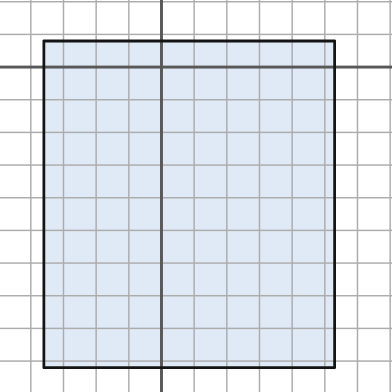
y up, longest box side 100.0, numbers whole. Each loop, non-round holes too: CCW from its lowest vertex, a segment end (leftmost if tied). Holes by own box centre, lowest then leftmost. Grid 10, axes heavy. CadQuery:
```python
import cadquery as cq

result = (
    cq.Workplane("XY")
    .moveTo(-36.0, -92.0)
    .lineTo(53.0, -92.0)
    .lineTo(53.0, 8.0)
    .lineTo(-36.0, 8.0)
    .close()
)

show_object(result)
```